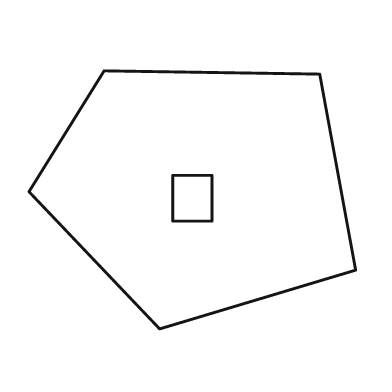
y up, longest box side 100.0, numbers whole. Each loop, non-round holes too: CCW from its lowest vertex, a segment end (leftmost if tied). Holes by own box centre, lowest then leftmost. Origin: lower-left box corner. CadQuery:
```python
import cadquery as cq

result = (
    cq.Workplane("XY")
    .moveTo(40.0, 0.0)
    .lineTo(100.0, 18.0)
    .lineTo(89.0, 78.0)
    .lineTo(23.0, 79.0)
    .lineTo(0.0, 42.0)
    .close()
    .moveTo(44.0, 33.0)
    .lineTo(56.0, 33.0)
    .lineTo(56.0, 47.0)
    .lineTo(44.0, 47.0)
    .close()
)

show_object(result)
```